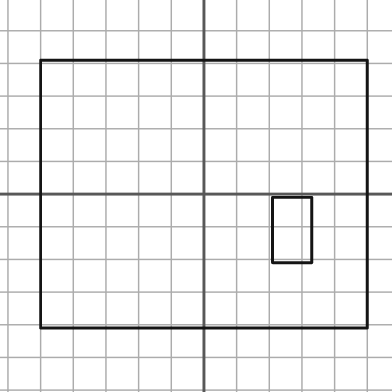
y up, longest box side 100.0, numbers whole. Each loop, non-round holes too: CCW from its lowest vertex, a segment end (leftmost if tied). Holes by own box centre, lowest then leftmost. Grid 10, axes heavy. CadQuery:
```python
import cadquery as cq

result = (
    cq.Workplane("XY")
    .moveTo(-50.0, -41.0)
    .lineTo(50.0, -41.0)
    .lineTo(50.0, 41.0)
    .lineTo(-50.0, 41.0)
    .close()
    .moveTo(21.0, -21.0)
    .lineTo(33.0, -21.0)
    .lineTo(33.0, -1.0)
    .lineTo(21.0, -1.0)
    .close()
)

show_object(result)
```